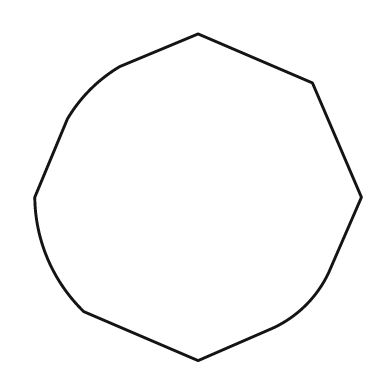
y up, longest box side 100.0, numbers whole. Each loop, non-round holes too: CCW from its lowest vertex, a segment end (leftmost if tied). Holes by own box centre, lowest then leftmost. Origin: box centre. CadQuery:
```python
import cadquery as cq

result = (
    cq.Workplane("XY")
    .moveTo(0.0, -50.0)
    .lineTo(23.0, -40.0)
    .threePointArc((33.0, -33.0), (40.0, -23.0))
    .lineTo(50.0, 0.0)
    .lineTo(35.0, 35.0)
    .lineTo(0.0, 50.0)
    .lineTo(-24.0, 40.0)
    .threePointArc((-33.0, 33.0), (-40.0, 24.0))
    .lineTo(-50.0, 0.0)
    .threePointArc((-46.0, -19.0), (-35.0, -35.0))
    .close()
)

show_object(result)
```